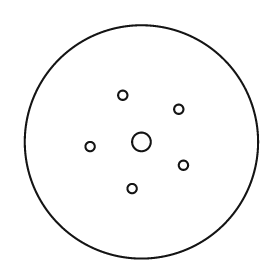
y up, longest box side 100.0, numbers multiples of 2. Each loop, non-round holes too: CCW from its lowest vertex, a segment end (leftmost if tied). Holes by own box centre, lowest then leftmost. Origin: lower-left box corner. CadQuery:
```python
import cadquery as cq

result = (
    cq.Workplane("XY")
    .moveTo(50.0, 50.0)
    .circle(50.0)
    .moveTo(46.0, 30.0)
    .circle(2.0)
    .moveTo(68.0, 40.0)
    .circle(2.0)
    .moveTo(28.0, 48.0)
    .circle(2.0)
    .moveTo(50.0, 50.0)
    .circle(4.0)
    .moveTo(66.0, 64.0)
    .circle(2.0)
    .moveTo(42.0, 70.0)
    .circle(2.0)
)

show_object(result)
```